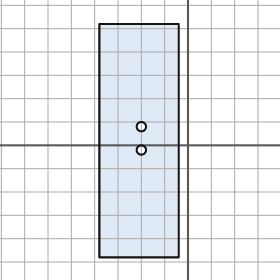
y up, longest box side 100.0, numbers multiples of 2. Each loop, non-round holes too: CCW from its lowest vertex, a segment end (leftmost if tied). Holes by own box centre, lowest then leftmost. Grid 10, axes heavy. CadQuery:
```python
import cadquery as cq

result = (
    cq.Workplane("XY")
    .moveTo(-38.0, -48.0)
    .lineTo(-4.0, -48.0)
    .lineTo(-4.0, 52.0)
    .lineTo(-38.0, 52.0)
    .close()
    .moveTo(-20.0, -2.0)
    .circle(2.0)
    .moveTo(-20.0, 8.0)
    .circle(2.0)
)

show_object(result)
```